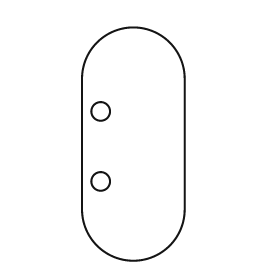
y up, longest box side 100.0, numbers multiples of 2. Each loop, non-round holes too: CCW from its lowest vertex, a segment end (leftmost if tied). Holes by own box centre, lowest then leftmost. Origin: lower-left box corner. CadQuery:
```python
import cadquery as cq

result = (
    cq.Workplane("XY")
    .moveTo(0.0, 22.0)
    .threePointArc((22.0, 0.0), (44.0, 22.0))
    .lineTo(44.0, 78.0)
    .threePointArc((22.0, 100.0), (0.0, 78.0))
    .close()
    .moveTo(8.0, 34.0)
    .circle(4.0)
    .moveTo(8.0, 64.0)
    .circle(4.0)
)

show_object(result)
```